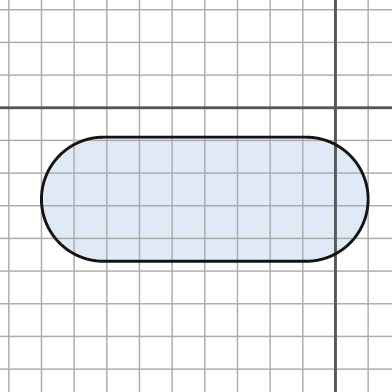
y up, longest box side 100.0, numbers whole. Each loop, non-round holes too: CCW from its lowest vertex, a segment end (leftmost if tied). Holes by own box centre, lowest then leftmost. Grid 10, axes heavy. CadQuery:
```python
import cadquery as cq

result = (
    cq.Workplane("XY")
    .moveTo(-71.0, -47.0)
    .lineTo(-9.0, -47.0)
    .threePointArc((10.0, -28.0), (-9.0, -9.0))
    .lineTo(-71.0, -9.0)
    .threePointArc((-90.0, -28.0), (-71.0, -47.0))
    .close()
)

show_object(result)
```